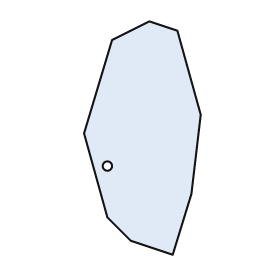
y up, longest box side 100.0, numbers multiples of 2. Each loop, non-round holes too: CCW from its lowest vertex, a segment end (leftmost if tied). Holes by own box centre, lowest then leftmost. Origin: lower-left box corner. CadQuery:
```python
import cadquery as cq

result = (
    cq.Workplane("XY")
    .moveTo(38.0, 0.0)
    .lineTo(46.0, 26.0)
    .lineTo(50.0, 60.0)
    .lineTo(40.0, 96.0)
    .lineTo(28.0, 100.0)
    .lineTo(12.0, 92.0)
    .lineTo(0.0, 52.0)
    .lineTo(10.0, 16.0)
    .lineTo(20.0, 6.0)
    .close()
    .moveTo(10.0, 38.0)
    .circle(2.0)
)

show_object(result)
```